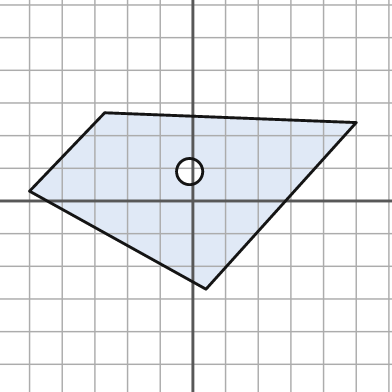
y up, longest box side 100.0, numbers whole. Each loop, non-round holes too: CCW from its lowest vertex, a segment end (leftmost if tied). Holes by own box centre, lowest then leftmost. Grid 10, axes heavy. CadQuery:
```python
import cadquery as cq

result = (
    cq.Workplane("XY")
    .moveTo(4.0, -27.0)
    .lineTo(50.0, 24.0)
    .lineTo(-27.0, 27.0)
    .lineTo(-50.0, 3.0)
    .close()
    .moveTo(-1.0, 9.0)
    .circle(4.0)
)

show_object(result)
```